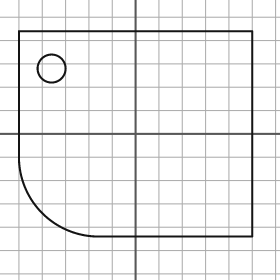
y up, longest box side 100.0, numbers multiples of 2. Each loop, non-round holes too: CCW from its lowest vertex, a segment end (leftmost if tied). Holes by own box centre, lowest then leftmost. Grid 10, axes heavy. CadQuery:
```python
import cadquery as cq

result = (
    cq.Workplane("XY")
    .moveTo(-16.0, -44.0)
    .lineTo(50.0, -44.0)
    .lineTo(50.0, 44.0)
    .lineTo(-50.0, 44.0)
    .lineTo(-50.0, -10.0)
    .threePointArc((-40.0, -34.0), (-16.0, -44.0))
    .close()
    .moveTo(-36.0, 28.0)
    .circle(6.0)
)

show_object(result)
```